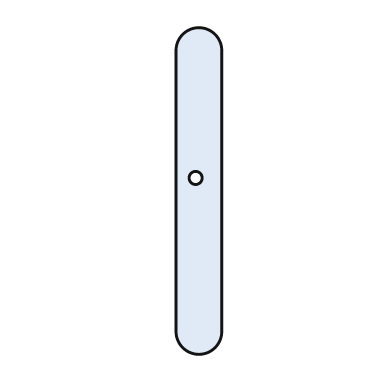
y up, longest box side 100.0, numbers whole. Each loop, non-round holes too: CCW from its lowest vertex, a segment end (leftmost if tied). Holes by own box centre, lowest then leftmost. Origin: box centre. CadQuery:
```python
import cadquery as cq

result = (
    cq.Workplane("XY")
    .moveTo(-7.0, -43.0)
    .threePointArc((0.0, -50.0), (7.0, -43.0))
    .lineTo(7.0, 43.0)
    .threePointArc((0.0, 50.0), (-7.0, 43.0))
    .close()
    .moveTo(-1.0, 4.0)
    .circle(2.0)
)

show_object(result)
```